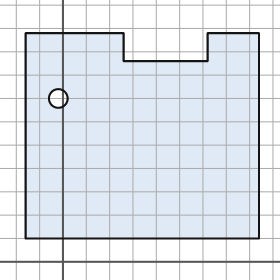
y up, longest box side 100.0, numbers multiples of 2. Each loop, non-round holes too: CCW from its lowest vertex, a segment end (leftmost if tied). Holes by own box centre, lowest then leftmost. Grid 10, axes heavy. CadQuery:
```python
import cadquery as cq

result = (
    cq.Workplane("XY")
    .moveTo(-16.0, 10.0)
    .lineTo(84.0, 10.0)
    .lineTo(84.0, 98.0)
    .lineTo(62.0, 98.0)
    .lineTo(62.0, 86.0)
    .lineTo(26.0, 86.0)
    .lineTo(26.0, 98.0)
    .lineTo(-16.0, 98.0)
    .close()
    .moveTo(-2.0, 70.0)
    .circle(4.0)
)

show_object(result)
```